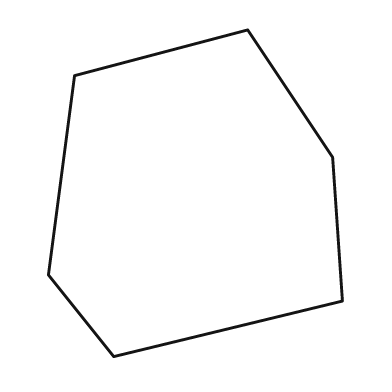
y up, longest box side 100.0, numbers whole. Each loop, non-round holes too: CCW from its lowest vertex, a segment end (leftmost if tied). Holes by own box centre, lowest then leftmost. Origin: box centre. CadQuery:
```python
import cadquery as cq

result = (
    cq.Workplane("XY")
    .moveTo(-25.0, -50.0)
    .lineTo(45.0, -33.0)
    .lineTo(42.0, 11.0)
    .lineTo(16.0, 50.0)
    .lineTo(-37.0, 36.0)
    .lineTo(-45.0, -25.0)
    .close()
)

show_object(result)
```